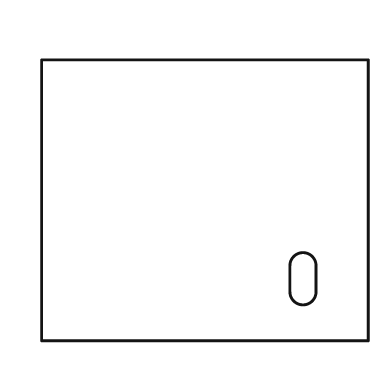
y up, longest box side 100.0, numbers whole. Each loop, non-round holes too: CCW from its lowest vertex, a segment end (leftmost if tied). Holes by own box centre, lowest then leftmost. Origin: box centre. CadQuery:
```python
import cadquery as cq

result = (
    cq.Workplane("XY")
    .moveTo(-50.0, -43.0)
    .lineTo(50.0, -43.0)
    .lineTo(50.0, 43.0)
    .lineTo(-50.0, 43.0)
    .close()
    .moveTo(26.0, -28.0)
    .threePointArc((30.0, -32.0), (34.0, -28.0))
    .lineTo(34.0, -20.0)
    .threePointArc((30.0, -16.0), (26.0, -20.0))
    .close()
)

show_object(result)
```